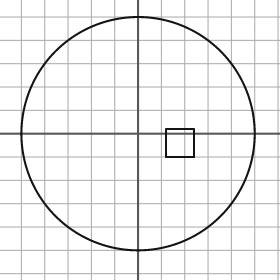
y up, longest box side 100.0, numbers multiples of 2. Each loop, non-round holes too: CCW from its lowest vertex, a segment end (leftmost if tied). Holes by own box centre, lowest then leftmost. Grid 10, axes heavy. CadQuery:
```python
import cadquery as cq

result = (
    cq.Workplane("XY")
    .moveTo(0.0, 0.0)
    .circle(50.0)
    .moveTo(12.0, -10.0)
    .lineTo(24.0, -10.0)
    .lineTo(24.0, 2.0)
    .lineTo(12.0, 2.0)
    .close()
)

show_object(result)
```